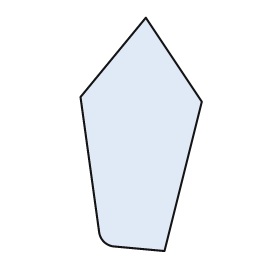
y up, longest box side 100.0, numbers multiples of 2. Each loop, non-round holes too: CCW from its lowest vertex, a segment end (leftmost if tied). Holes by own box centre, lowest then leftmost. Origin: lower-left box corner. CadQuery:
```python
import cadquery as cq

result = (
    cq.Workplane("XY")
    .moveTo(36.0, 0.0)
    .lineTo(52.0, 64.0)
    .lineTo(28.0, 100.0)
    .lineTo(0.0, 66.0)
    .lineTo(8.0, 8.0)
    .threePointArc((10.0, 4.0), (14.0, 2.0))
    .close()
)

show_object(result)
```